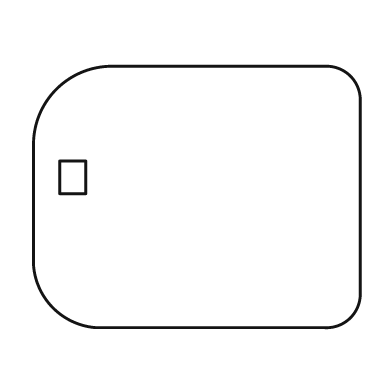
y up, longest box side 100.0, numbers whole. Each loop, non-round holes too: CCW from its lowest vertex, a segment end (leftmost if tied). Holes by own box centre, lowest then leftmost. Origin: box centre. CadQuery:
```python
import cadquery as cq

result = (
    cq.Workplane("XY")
    .moveTo(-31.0, -40.0)
    .lineTo(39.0, -40.0)
    .threePointArc((47.0, -37.0), (50.0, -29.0))
    .lineTo(50.0, 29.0)
    .threePointArc((47.0, 37.0), (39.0, 40.0))
    .lineTo(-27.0, 40.0)
    .threePointArc((-43.0, 33.0), (-50.0, 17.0))
    .lineTo(-50.0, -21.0)
    .threePointArc((-44.0, -34.0), (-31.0, -40.0))
    .close()
    .moveTo(-42.0, 1.0)
    .lineTo(-34.0, 1.0)
    .lineTo(-34.0, 11.0)
    .lineTo(-42.0, 11.0)
    .close()
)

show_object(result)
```